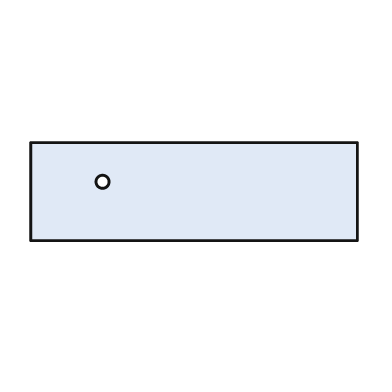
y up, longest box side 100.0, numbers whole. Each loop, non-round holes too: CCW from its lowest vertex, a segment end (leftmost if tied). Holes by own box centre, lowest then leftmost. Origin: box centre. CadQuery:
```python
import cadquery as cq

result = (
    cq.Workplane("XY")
    .moveTo(-50.0, -15.0)
    .lineTo(50.0, -15.0)
    .lineTo(50.0, 15.0)
    .lineTo(-50.0, 15.0)
    .close()
    .moveTo(-28.0, 3.0)
    .circle(2.0)
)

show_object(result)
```